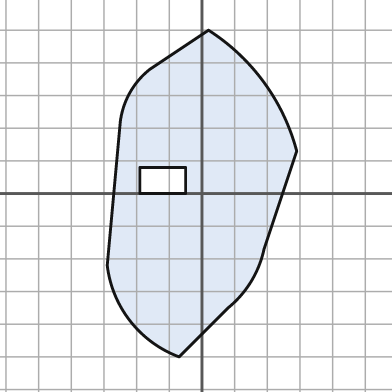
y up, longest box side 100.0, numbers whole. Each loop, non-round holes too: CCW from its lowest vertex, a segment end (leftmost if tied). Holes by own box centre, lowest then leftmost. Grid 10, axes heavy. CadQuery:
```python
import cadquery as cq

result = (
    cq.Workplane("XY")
    .moveTo(-7.0, -50.0)
    .lineTo(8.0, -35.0)
    .threePointArc((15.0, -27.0), (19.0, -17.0))
    .lineTo(29.0, 13.0)
    .threePointArc((19.0, 34.0), (2.0, 50.0))
    .lineTo(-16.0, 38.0)
    .threePointArc((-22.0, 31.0), (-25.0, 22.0))
    .lineTo(-29.0, -22.0)
    .threePointArc((-22.0, -39.0), (-7.0, -50.0))
    .close()
    .moveTo(-19.0, 0.0)
    .lineTo(-5.0, 0.0)
    .lineTo(-5.0, 8.0)
    .lineTo(-19.0, 8.0)
    .close()
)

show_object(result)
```